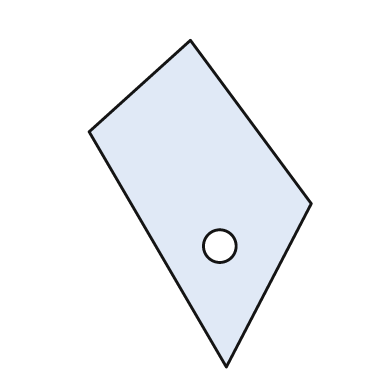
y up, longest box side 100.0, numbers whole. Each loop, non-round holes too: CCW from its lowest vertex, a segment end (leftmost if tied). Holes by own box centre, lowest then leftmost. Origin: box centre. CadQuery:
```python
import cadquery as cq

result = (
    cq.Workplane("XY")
    .moveTo(8.0, -50.0)
    .lineTo(34.0, 0.0)
    .lineTo(-3.0, 50.0)
    .lineTo(-34.0, 22.0)
    .close()
    .moveTo(6.0, -13.0)
    .circle(5.0)
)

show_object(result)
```